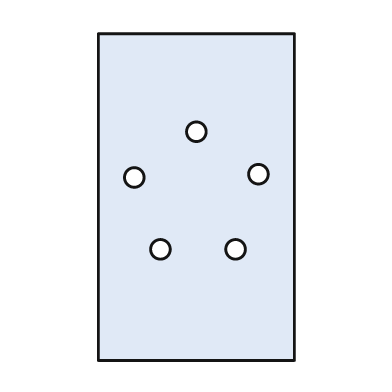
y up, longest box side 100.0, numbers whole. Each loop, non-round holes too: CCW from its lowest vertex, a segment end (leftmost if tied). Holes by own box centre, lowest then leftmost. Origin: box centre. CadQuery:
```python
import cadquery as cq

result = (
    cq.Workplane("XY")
    .moveTo(-30.0, -50.0)
    .lineTo(30.0, -50.0)
    .lineTo(30.0, 50.0)
    .lineTo(-30.0, 50.0)
    .close()
    .moveTo(-11.0, -16.0)
    .circle(3.0)
    .moveTo(12.0, -16.0)
    .circle(3.0)
    .moveTo(-19.0, 6.0)
    .circle(3.0)
    .moveTo(19.0, 7.0)
    .circle(3.0)
    .moveTo(0.0, 20.0)
    .circle(3.0)
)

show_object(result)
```